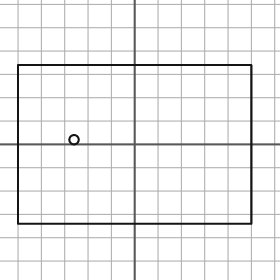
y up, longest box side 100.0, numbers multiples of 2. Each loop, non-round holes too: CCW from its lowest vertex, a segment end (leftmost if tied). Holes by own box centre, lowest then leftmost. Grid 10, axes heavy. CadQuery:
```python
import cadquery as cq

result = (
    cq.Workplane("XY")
    .moveTo(-50.0, -34.0)
    .lineTo(50.0, -34.0)
    .lineTo(50.0, 34.0)
    .lineTo(-50.0, 34.0)
    .close()
    .moveTo(-26.0, 2.0)
    .circle(2.0)
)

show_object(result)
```